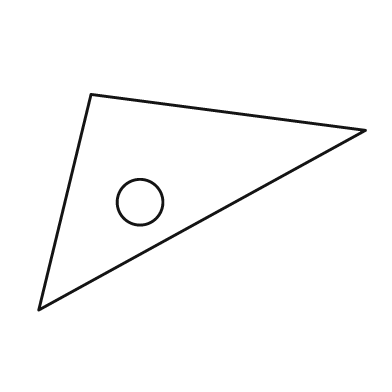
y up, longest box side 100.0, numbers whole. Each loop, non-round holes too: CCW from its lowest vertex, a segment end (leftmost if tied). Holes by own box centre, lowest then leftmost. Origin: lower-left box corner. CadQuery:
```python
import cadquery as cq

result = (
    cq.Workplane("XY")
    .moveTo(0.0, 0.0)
    .lineTo(100.0, 55.0)
    .lineTo(16.0, 66.0)
    .close()
    .moveTo(31.0, 33.0)
    .circle(7.0)
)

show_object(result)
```